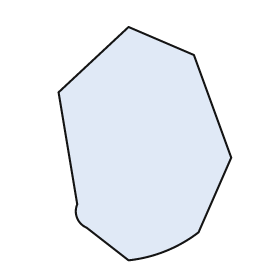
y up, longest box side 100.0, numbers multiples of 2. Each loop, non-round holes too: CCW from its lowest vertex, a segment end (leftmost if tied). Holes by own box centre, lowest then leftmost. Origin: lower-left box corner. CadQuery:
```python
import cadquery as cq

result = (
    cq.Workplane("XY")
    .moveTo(30.0, 0.0)
    .threePointArc((46.0, 4.0), (60.0, 12.0))
    .lineTo(74.0, 44.0)
    .lineTo(58.0, 88.0)
    .lineTo(30.0, 100.0)
    .lineTo(0.0, 72.0)
    .lineTo(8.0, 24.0)
    .threePointArc((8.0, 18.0), (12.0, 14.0))
    .close()
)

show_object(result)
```